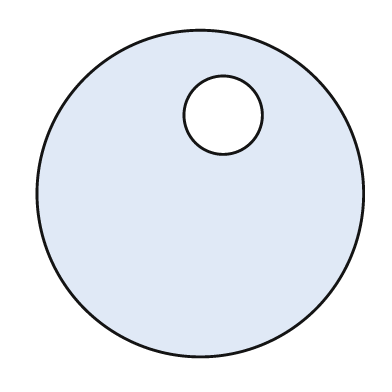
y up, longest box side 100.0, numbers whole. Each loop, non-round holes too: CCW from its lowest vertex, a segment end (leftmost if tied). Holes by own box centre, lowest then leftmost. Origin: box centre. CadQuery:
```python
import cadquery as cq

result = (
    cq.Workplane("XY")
    .moveTo(0.0, 0.0)
    .circle(50.0)
    .moveTo(7.0, 24.0)
    .circle(12.0)
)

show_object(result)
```